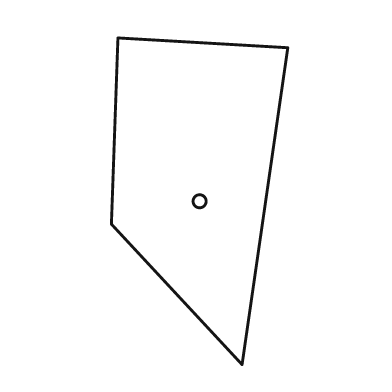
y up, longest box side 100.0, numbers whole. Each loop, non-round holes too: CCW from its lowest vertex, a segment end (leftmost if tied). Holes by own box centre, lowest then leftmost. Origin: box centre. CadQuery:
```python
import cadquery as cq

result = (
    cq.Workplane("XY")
    .moveTo(13.0, -50.0)
    .lineTo(27.0, 47.0)
    .lineTo(-25.0, 50.0)
    .lineTo(-27.0, -7.0)
    .close()
    .moveTo(0.0, 0.0)
    .circle(2.0)
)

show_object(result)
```